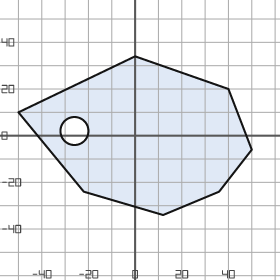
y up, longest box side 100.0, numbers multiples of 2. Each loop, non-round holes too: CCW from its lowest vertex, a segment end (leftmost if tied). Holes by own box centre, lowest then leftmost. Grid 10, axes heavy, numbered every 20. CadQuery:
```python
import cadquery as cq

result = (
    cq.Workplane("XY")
    .moveTo(12.0, -34.0)
    .lineTo(36.0, -24.0)
    .lineTo(50.0, -6.0)
    .lineTo(40.0, 20.0)
    .lineTo(0.0, 34.0)
    .lineTo(-50.0, 10.0)
    .lineTo(-22.0, -24.0)
    .close()
    .moveTo(-26.0, 2.0)
    .circle(6.0)
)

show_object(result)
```